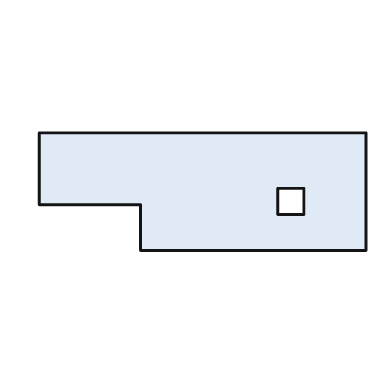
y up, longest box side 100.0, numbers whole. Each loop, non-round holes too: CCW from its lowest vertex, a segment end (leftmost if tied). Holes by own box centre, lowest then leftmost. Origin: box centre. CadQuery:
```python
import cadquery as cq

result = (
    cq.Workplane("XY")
    .moveTo(-19.0, -18.0)
    .lineTo(50.0, -18.0)
    .lineTo(50.0, 18.0)
    .lineTo(-50.0, 18.0)
    .lineTo(-50.0, -4.0)
    .lineTo(-19.0, -4.0)
    .close()
    .moveTo(23.0, -7.0)
    .lineTo(31.0, -7.0)
    .lineTo(31.0, 1.0)
    .lineTo(23.0, 1.0)
    .close()
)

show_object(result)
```